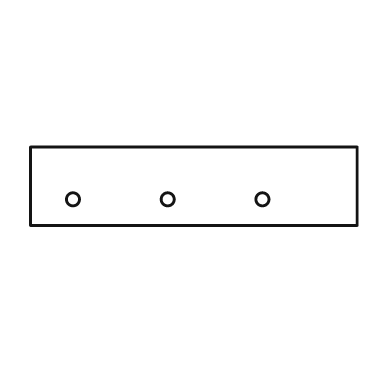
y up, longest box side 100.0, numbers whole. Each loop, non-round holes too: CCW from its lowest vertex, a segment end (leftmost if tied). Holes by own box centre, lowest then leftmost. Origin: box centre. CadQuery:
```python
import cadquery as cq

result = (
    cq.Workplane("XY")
    .moveTo(-50.0, -12.0)
    .lineTo(50.0, -12.0)
    .lineTo(50.0, 12.0)
    .lineTo(-50.0, 12.0)
    .close()
    .moveTo(-37.0, -4.0)
    .circle(2.0)
    .moveTo(-8.0, -4.0)
    .circle(2.0)
    .moveTo(21.0, -4.0)
    .circle(2.0)
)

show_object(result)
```